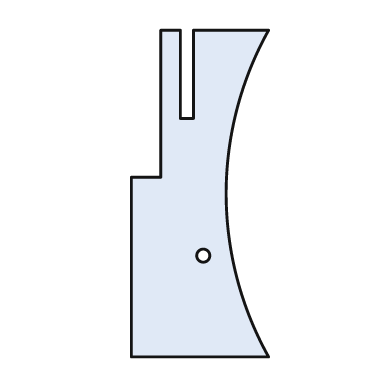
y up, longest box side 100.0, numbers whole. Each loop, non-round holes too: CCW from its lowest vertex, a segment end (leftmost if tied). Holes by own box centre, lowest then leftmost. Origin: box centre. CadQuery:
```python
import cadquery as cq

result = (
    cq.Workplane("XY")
    .moveTo(-21.0, -50.0)
    .lineTo(21.0, -50.0)
    .threePointArc((8.0, 0.0), (21.0, 50.0))
    .lineTo(-2.0, 50.0)
    .lineTo(-2.0, 23.0)
    .lineTo(-6.0, 23.0)
    .lineTo(-6.0, 50.0)
    .lineTo(-12.0, 50.0)
    .lineTo(-12.0, 5.0)
    .lineTo(-21.0, 5.0)
    .close()
    .moveTo(1.0, -19.0)
    .circle(2.0)
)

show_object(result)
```